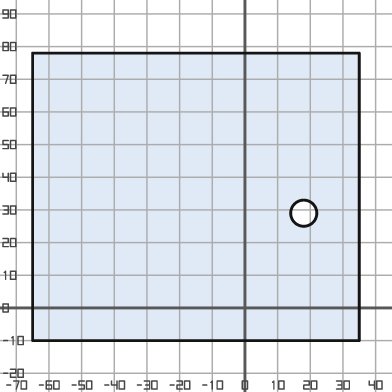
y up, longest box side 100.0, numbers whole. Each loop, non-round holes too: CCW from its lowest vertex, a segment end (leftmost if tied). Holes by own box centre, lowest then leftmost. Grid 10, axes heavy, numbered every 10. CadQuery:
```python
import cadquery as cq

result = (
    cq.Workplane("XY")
    .moveTo(-65.0, -10.0)
    .lineTo(35.0, -10.0)
    .lineTo(35.0, 78.0)
    .lineTo(-65.0, 78.0)
    .close()
    .moveTo(18.0, 29.0)
    .circle(4.0)
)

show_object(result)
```